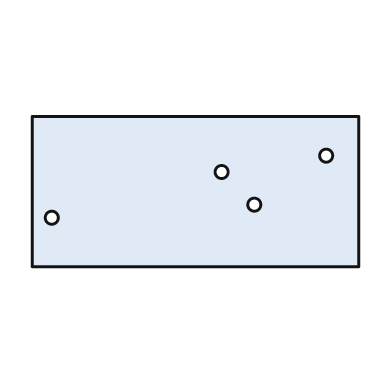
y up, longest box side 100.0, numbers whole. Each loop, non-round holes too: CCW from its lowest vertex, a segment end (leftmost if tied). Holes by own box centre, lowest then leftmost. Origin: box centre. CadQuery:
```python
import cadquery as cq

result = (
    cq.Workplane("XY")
    .moveTo(-50.0, -23.0)
    .lineTo(50.0, -23.0)
    .lineTo(50.0, 23.0)
    .lineTo(-50.0, 23.0)
    .close()
    .moveTo(-44.0, -8.0)
    .circle(2.0)
    .moveTo(18.0, -4.0)
    .circle(2.0)
    .moveTo(8.0, 6.0)
    .circle(2.0)
    .moveTo(40.0, 11.0)
    .circle(2.0)
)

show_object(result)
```